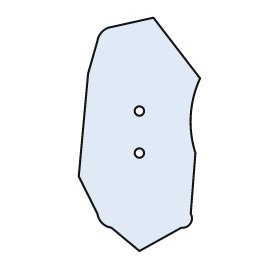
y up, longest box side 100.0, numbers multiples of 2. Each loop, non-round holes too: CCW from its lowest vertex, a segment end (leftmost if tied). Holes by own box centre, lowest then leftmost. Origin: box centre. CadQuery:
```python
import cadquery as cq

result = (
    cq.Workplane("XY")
    .moveTo(0.0, -50.0)
    .lineTo(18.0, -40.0)
    .threePointArc((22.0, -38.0), (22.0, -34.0))
    .lineTo(24.0, -8.0)
    .threePointArc((22.0, 8.0), (26.0, 24.0))
    .lineTo(6.0, 50.0)
    .lineTo(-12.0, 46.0)
    .threePointArc((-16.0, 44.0), (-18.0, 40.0))
    .lineTo(-22.0, 26.0)
    .lineTo(-26.0, -18.0)
    .lineTo(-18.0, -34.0)
    .threePointArc((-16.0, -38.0), (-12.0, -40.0))
    .close()
    .moveTo(0.0, -8.0)
    .circle(2.0)
    .moveTo(0.0, 10.0)
    .circle(2.0)
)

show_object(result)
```